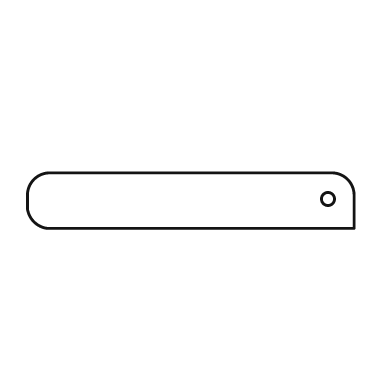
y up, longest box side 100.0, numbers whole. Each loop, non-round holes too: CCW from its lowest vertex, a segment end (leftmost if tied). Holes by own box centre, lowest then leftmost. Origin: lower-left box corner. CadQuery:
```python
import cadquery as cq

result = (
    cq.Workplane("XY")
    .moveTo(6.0, 0.0)
    .lineTo(100.0, 0.0)
    .lineTo(100.0, 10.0)
    .threePointArc((98.0, 15.0), (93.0, 17.0))
    .lineTo(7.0, 17.0)
    .threePointArc((2.0, 15.0), (0.0, 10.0))
    .lineTo(0.0, 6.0)
    .threePointArc((2.0, 2.0), (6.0, 0.0))
    .close()
    .moveTo(92.0, 9.0)
    .circle(2.0)
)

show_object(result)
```